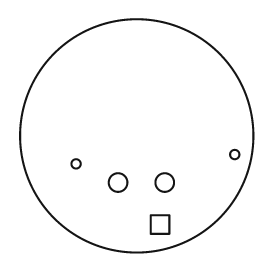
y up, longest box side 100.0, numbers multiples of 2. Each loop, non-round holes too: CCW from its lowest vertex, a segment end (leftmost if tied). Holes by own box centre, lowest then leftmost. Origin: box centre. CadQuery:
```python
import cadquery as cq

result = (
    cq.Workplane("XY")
    .moveTo(0.0, 0.0)
    .circle(50.0)
    .moveTo(6.0, -42.0)
    .lineTo(14.0, -42.0)
    .lineTo(14.0, -34.0)
    .lineTo(6.0, -34.0)
    .close()
    .moveTo(-8.0, -20.0)
    .circle(4.0)
    .moveTo(12.0, -20.0)
    .circle(4.0)
    .moveTo(-26.0, -12.0)
    .circle(2.0)
    .moveTo(42.0, -8.0)
    .circle(2.0)
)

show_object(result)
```